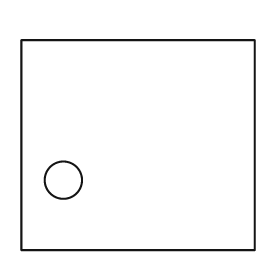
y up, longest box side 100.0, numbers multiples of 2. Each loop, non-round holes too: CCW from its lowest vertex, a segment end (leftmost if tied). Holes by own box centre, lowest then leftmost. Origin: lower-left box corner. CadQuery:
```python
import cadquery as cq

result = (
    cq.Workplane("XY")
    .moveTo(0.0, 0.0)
    .lineTo(100.0, 0.0)
    .lineTo(100.0, 90.0)
    .lineTo(0.0, 90.0)
    .close()
    .moveTo(18.0, 30.0)
    .circle(8.0)
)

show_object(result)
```